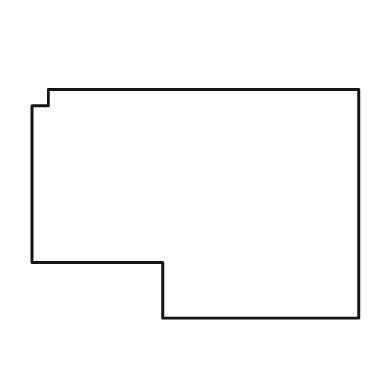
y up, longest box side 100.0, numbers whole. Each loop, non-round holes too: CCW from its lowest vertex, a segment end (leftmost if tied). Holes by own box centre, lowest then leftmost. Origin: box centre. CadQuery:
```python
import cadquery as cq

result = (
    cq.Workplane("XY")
    .moveTo(-10.0, -35.0)
    .lineTo(50.0, -35.0)
    .lineTo(50.0, 35.0)
    .lineTo(-45.0, 35.0)
    .lineTo(-45.0, 30.0)
    .lineTo(-50.0, 30.0)
    .lineTo(-50.0, -18.0)
    .lineTo(-10.0, -18.0)
    .close()
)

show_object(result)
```